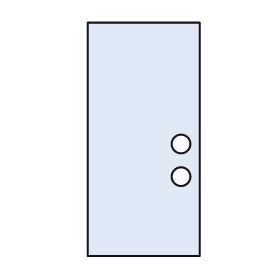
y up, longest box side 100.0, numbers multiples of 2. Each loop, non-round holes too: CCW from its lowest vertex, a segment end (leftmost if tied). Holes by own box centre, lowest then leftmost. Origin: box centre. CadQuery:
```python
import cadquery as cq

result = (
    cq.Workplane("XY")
    .moveTo(-24.0, -50.0)
    .lineTo(24.0, -50.0)
    .lineTo(24.0, 50.0)
    .lineTo(-24.0, 50.0)
    .close()
    .moveTo(16.0, -16.0)
    .circle(4.0)
    .moveTo(16.0, -2.0)
    .circle(4.0)
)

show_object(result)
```